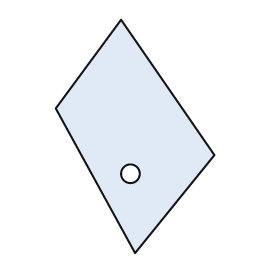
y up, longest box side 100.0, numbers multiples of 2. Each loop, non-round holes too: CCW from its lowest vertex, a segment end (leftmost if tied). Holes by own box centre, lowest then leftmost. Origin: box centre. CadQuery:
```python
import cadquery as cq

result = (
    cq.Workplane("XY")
    .moveTo(0.0, -50.0)
    .lineTo(34.0, -8.0)
    .lineTo(-6.0, 50.0)
    .lineTo(-34.0, 12.0)
    .close()
    .moveTo(-2.0, -16.0)
    .circle(4.0)
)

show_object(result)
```